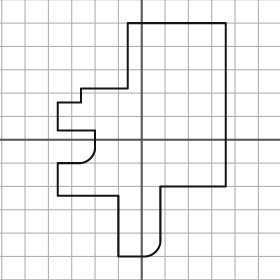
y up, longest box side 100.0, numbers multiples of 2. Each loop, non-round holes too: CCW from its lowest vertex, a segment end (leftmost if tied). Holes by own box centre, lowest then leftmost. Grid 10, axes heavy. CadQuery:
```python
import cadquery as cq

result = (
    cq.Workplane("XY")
    .moveTo(-10.0, -50.0)
    .lineTo(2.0, -50.0)
    .threePointArc((6.0, -48.0), (8.0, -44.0))
    .lineTo(8.0, -20.0)
    .lineTo(36.0, -20.0)
    .lineTo(36.0, 50.0)
    .lineTo(-6.0, 50.0)
    .lineTo(-6.0, 22.0)
    .lineTo(-26.0, 22.0)
    .lineTo(-26.0, 16.0)
    .lineTo(-36.0, 16.0)
    .lineTo(-36.0, 4.0)
    .lineTo(-20.0, 4.0)
    .lineTo(-20.0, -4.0)
    .threePointArc((-22.0, -8.0), (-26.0, -10.0))
    .lineTo(-36.0, -10.0)
    .lineTo(-36.0, -24.0)
    .lineTo(-10.0, -24.0)
    .close()
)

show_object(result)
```